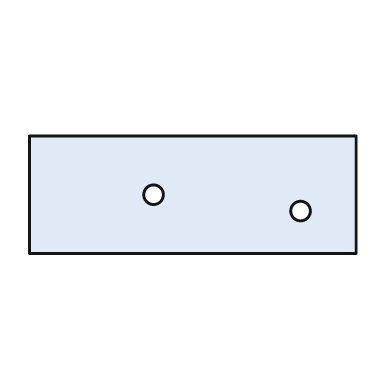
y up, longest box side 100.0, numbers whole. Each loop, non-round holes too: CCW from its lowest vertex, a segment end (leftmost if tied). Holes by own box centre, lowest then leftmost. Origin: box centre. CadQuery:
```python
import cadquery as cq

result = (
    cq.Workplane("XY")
    .moveTo(-50.0, -18.0)
    .lineTo(50.0, -18.0)
    .lineTo(50.0, 18.0)
    .lineTo(-50.0, 18.0)
    .close()
    .moveTo(33.0, -5.0)
    .circle(3.0)
    .moveTo(-12.0, 0.0)
    .circle(3.0)
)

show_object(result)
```